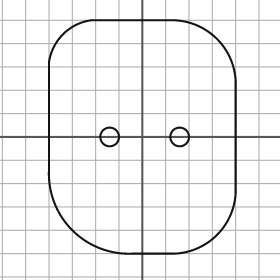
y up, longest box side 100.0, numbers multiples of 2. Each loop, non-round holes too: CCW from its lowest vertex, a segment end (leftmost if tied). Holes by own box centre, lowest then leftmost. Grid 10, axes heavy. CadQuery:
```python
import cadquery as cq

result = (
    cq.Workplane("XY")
    .moveTo(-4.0, -50.0)
    .lineTo(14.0, -50.0)
    .threePointArc((32.0, -42.0), (40.0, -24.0))
    .lineTo(40.0, 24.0)
    .threePointArc((32.0, 42.0), (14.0, 50.0))
    .lineTo(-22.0, 50.0)
    .threePointArc((-34.0, 44.0), (-40.0, 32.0))
    .lineTo(-40.0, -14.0)
    .threePointArc((-30.0, -40.0), (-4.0, -50.0))
    .close()
    .moveTo(-14.0, 0.0)
    .circle(4.0)
    .moveTo(16.0, 0.0)
    .circle(4.0)
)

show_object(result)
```